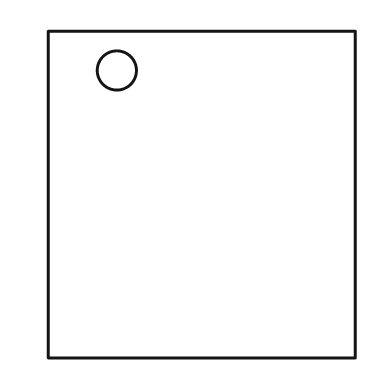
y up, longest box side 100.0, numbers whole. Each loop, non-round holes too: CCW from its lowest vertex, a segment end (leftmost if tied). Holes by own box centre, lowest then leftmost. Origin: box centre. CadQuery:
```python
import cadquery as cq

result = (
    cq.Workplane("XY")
    .moveTo(-47.0, -50.0)
    .lineTo(47.0, -50.0)
    .lineTo(47.0, 50.0)
    .lineTo(-47.0, 50.0)
    .close()
    .moveTo(-26.0, 38.0)
    .circle(6.0)
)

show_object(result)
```